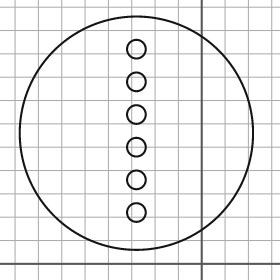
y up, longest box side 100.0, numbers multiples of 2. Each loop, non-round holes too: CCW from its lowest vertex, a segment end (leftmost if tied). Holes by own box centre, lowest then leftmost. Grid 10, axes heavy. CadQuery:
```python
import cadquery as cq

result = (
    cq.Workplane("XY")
    .moveTo(-28.0, 56.0)
    .circle(50.0)
    .moveTo(-28.0, 22.0)
    .circle(4.0)
    .moveTo(-28.0, 36.0)
    .circle(4.0)
    .moveTo(-28.0, 50.0)
    .circle(4.0)
    .moveTo(-28.0, 64.0)
    .circle(4.0)
    .moveTo(-28.0, 78.0)
    .circle(4.0)
    .moveTo(-28.0, 92.0)
    .circle(4.0)
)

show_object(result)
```